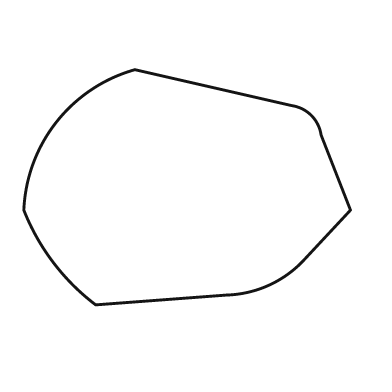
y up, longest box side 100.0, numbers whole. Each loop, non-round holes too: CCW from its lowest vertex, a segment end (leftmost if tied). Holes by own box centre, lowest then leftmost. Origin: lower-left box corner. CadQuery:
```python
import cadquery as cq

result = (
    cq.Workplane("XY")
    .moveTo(22.0, 0.0)
    .lineTo(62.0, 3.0)
    .threePointArc((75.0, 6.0), (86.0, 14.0))
    .lineTo(100.0, 29.0)
    .lineTo(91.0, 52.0)
    .threePointArc((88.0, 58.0), (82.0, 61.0))
    .lineTo(34.0, 72.0)
    .threePointArc((10.0, 56.0), (0.0, 29.0))
    .threePointArc((9.0, 13.0), (22.0, 0.0))
    .close()
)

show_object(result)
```